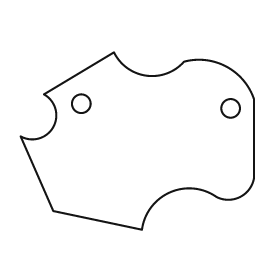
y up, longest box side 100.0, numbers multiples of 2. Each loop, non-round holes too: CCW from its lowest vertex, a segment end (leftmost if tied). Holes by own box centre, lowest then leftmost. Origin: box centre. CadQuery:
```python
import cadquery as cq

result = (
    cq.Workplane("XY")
    .moveTo(2.0, -38.0)
    .threePointArc((14.0, -22.0), (34.0, -24.0))
    .threePointArc((44.0, -24.0), (50.0, -16.0))
    .lineTo(50.0, 18.0)
    .threePointArc((38.0, 32.0), (20.0, 34.0))
    .threePointArc((4.0, 28.0), (-10.0, 38.0))
    .lineTo(-40.0, 20.0)
    .threePointArc((-36.0, 6.0), (-50.0, 2.0))
    .lineTo(-36.0, -30.0)
    .close()
    .moveTo(40.0, 14.0)
    .circle(4.0)
    .moveTo(-24.0, 16.0)
    .circle(4.0)
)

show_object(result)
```